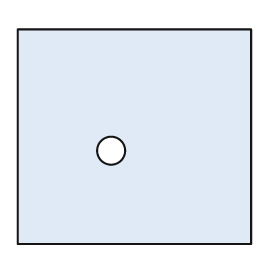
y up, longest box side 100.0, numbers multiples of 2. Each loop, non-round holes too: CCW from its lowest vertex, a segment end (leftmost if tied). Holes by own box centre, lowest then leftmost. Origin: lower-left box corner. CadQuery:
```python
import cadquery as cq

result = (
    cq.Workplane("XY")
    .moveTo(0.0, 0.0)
    .lineTo(100.0, 0.0)
    .lineTo(100.0, 92.0)
    .lineTo(0.0, 92.0)
    .close()
    .moveTo(40.0, 40.0)
    .circle(6.0)
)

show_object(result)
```